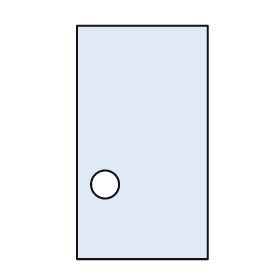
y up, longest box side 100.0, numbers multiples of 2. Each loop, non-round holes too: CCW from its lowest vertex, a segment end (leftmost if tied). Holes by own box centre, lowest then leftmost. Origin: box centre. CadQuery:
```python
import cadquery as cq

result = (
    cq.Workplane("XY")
    .moveTo(-28.0, -50.0)
    .lineTo(28.0, -50.0)
    .lineTo(28.0, 50.0)
    .lineTo(-28.0, 50.0)
    .close()
    .moveTo(-16.0, -18.0)
    .circle(6.0)
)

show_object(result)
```